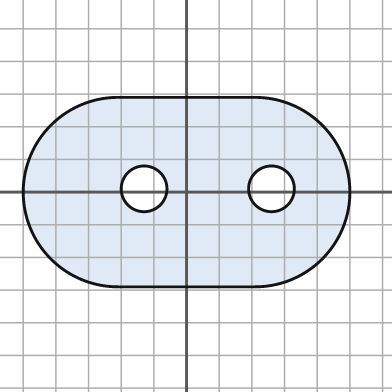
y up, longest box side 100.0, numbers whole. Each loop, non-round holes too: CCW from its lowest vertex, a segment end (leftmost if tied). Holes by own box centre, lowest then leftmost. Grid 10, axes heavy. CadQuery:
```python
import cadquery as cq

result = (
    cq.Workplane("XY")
    .moveTo(-21.0, -29.0)
    .lineTo(21.0, -29.0)
    .threePointArc((50.0, 0.0), (21.0, 29.0))
    .lineTo(-21.0, 29.0)
    .threePointArc((-50.0, 0.0), (-21.0, -29.0))
    .close()
    .moveTo(-13.0, 1.0)
    .circle(7.0)
    .moveTo(26.0, 1.0)
    .circle(7.0)
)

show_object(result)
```